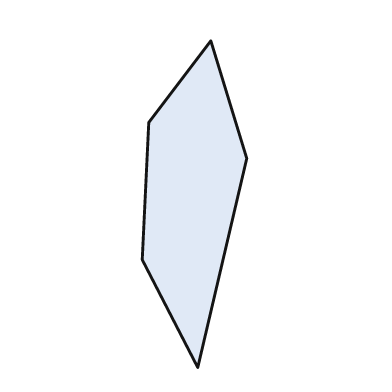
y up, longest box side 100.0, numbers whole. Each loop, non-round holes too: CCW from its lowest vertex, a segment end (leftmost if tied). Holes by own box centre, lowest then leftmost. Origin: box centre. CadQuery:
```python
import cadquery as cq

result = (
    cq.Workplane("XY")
    .moveTo(1.0, -50.0)
    .lineTo(16.0, 14.0)
    .lineTo(5.0, 50.0)
    .lineTo(-14.0, 25.0)
    .lineTo(-16.0, -17.0)
    .close()
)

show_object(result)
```